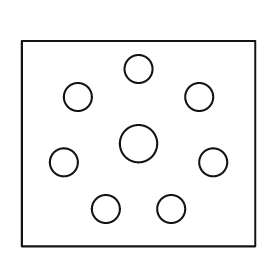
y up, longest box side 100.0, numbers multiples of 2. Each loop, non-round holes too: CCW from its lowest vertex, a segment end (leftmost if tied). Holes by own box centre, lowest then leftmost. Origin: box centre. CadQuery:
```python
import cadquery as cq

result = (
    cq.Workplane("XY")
    .moveTo(-50.0, -44.0)
    .lineTo(50.0, -44.0)
    .lineTo(50.0, 44.0)
    .lineTo(-50.0, 44.0)
    .close()
    .moveTo(-14.0, -28.0)
    .circle(6.0)
    .moveTo(14.0, -28.0)
    .circle(6.0)
    .moveTo(-32.0, -8.0)
    .circle(6.0)
    .moveTo(32.0, -8.0)
    .circle(6.0)
    .moveTo(0.0, 0.0)
    .circle(8.0)
    .moveTo(-26.0, 20.0)
    .circle(6.0)
    .moveTo(26.0, 20.0)
    .circle(6.0)
    .moveTo(0.0, 32.0)
    .circle(6.0)
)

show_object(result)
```